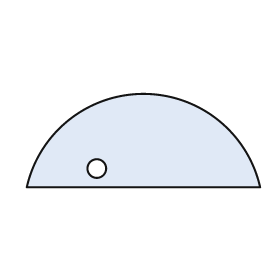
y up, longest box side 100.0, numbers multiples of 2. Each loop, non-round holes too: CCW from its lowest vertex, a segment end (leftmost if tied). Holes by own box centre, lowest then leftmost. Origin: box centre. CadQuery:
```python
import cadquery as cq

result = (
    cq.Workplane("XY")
    .moveTo(-50.0, -20.0)
    .lineTo(50.0, -20.0)
    .threePointArc((0.0, 20.0), (-50.0, -20.0))
    .close()
    .moveTo(-20.0, -12.0)
    .circle(4.0)
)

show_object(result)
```